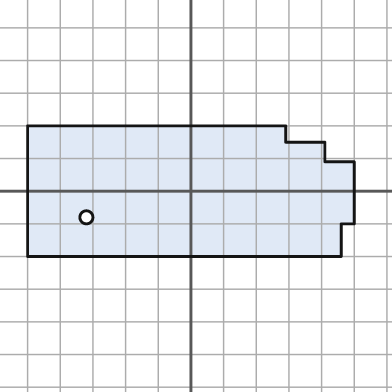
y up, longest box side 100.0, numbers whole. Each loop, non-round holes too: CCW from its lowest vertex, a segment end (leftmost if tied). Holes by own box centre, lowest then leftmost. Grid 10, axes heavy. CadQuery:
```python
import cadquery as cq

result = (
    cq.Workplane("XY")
    .moveTo(-50.0, -20.0)
    .lineTo(46.0, -20.0)
    .lineTo(46.0, -10.0)
    .lineTo(50.0, -10.0)
    .lineTo(50.0, 9.0)
    .lineTo(41.0, 9.0)
    .lineTo(41.0, 15.0)
    .lineTo(29.0, 15.0)
    .lineTo(29.0, 20.0)
    .lineTo(-50.0, 20.0)
    .close()
    .moveTo(-32.0, -8.0)
    .circle(2.0)
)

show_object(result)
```